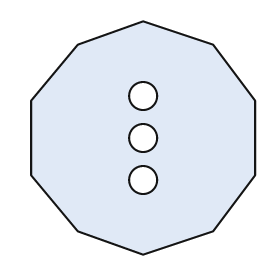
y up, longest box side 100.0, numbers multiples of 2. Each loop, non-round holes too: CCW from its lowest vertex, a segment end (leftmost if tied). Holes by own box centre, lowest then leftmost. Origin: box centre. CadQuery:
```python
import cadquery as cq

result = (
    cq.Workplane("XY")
    .moveTo(0.0, -50.0)
    .lineTo(30.0, -40.0)
    .lineTo(48.0, -16.0)
    .lineTo(48.0, 16.0)
    .lineTo(30.0, 40.0)
    .lineTo(0.0, 50.0)
    .lineTo(-28.0, 40.0)
    .lineTo(-48.0, 16.0)
    .lineTo(-48.0, -16.0)
    .lineTo(-28.0, -40.0)
    .close()
    .moveTo(0.0, -18.0)
    .circle(6.0)
    .moveTo(0.0, 0.0)
    .circle(6.0)
    .moveTo(0.0, 18.0)
    .circle(6.0)
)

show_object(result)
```